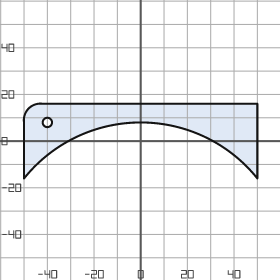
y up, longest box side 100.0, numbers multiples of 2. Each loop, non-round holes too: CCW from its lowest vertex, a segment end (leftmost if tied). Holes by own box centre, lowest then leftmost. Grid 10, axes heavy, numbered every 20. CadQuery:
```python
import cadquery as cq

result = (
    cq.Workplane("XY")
    .moveTo(-50.0, -16.0)
    .threePointArc((0.0, 8.0), (50.0, -16.0))
    .lineTo(50.0, 16.0)
    .lineTo(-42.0, 16.0)
    .threePointArc((-48.0, 14.0), (-50.0, 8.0))
    .close()
    .moveTo(-40.0, 8.0)
    .circle(2.0)
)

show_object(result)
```